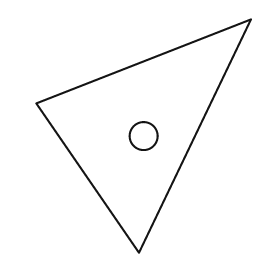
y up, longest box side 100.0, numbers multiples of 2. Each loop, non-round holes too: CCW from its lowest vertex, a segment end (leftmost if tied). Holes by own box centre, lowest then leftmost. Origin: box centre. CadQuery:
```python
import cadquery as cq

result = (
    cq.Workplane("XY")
    .moveTo(-2.0, -50.0)
    .lineTo(46.0, 50.0)
    .lineTo(-46.0, 14.0)
    .close()
    .moveTo(0.0, 0.0)
    .circle(6.0)
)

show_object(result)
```